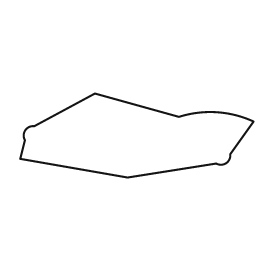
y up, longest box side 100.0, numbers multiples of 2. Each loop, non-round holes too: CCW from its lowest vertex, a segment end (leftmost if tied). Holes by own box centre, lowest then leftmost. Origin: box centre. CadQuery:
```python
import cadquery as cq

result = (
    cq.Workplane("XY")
    .moveTo(-4.0, -18.0)
    .lineTo(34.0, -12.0)
    .threePointArc((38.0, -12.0), (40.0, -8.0))
    .lineTo(50.0, 6.0)
    .threePointArc((34.0, 10.0), (18.0, 8.0))
    .lineTo(-18.0, 18.0)
    .lineTo(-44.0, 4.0)
    .threePointArc((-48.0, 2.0), (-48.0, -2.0))
    .lineTo(-50.0, -10.0)
    .close()
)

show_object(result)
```